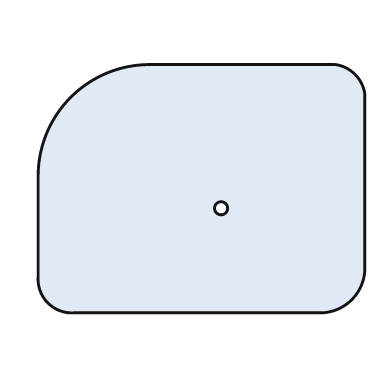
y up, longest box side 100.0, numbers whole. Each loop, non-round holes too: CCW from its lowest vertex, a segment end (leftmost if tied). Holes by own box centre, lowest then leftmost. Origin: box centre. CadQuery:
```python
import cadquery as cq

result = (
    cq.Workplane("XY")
    .moveTo(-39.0, -38.0)
    .lineTo(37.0, -38.0)
    .threePointArc((46.0, -34.0), (50.0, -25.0))
    .lineTo(50.0, 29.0)
    .threePointArc((47.0, 35.0), (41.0, 38.0))
    .lineTo(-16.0, 38.0)
    .threePointArc((-40.0, 28.0), (-50.0, 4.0))
    .lineTo(-50.0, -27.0)
    .threePointArc((-47.0, -35.0), (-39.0, -38.0))
    .close()
    .moveTo(6.0, -6.0)
    .circle(2.0)
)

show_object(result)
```